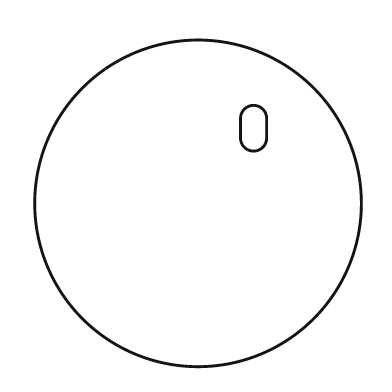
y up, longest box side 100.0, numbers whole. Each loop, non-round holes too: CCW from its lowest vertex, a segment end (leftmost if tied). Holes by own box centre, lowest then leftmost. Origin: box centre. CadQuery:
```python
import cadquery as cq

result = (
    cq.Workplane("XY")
    .moveTo(0.0, 0.0)
    .circle(50.0)
    .moveTo(13.0, 20.0)
    .threePointArc((17.0, 16.0), (21.0, 20.0))
    .lineTo(21.0, 26.0)
    .threePointArc((17.0, 30.0), (13.0, 26.0))
    .close()
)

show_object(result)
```